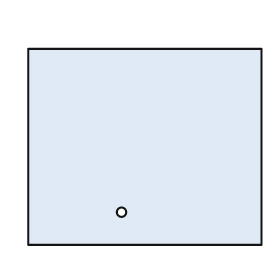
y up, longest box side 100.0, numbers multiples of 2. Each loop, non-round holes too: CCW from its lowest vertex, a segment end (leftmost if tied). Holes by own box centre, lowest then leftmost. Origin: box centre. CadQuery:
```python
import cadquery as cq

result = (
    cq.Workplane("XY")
    .moveTo(-50.0, -42.0)
    .lineTo(50.0, -42.0)
    .lineTo(50.0, 42.0)
    .lineTo(-50.0, 42.0)
    .close()
    .moveTo(-10.0, -28.0)
    .circle(2.0)
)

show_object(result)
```